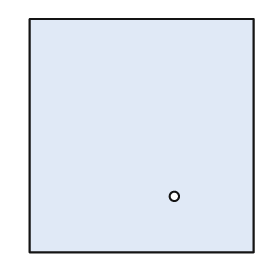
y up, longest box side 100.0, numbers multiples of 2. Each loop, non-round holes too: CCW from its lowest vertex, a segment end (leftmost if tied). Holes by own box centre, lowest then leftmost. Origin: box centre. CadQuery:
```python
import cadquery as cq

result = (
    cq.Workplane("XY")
    .moveTo(-48.0, -50.0)
    .lineTo(48.0, -50.0)
    .lineTo(48.0, 50.0)
    .lineTo(-48.0, 50.0)
    .close()
    .moveTo(14.0, -26.0)
    .circle(2.0)
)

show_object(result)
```